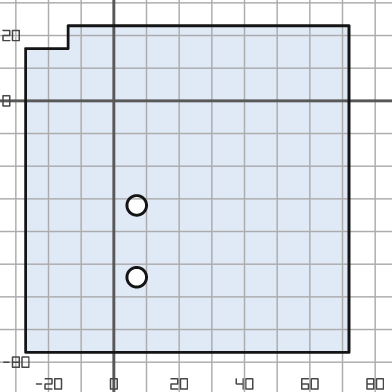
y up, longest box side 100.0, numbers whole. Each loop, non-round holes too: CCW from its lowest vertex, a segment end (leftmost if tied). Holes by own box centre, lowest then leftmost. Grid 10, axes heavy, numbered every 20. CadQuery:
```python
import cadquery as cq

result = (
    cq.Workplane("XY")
    .moveTo(-27.0, -77.0)
    .lineTo(72.0, -77.0)
    .lineTo(72.0, 23.0)
    .lineTo(-14.0, 23.0)
    .lineTo(-14.0, 16.0)
    .lineTo(-27.0, 16.0)
    .close()
    .moveTo(7.0, -54.0)
    .circle(3.0)
    .moveTo(7.0, -32.0)
    .circle(3.0)
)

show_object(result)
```